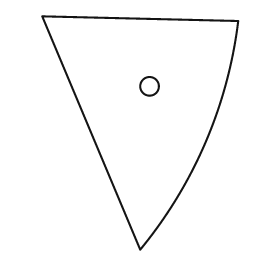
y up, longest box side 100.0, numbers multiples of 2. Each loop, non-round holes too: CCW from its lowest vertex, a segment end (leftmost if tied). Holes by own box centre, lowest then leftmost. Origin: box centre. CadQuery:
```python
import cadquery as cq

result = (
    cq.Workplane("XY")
    .moveTo(0.0, -50.0)
    .threePointArc((28.0, -4.0), (42.0, 48.0))
    .lineTo(-42.0, 50.0)
    .close()
    .moveTo(4.0, 20.0)
    .circle(4.0)
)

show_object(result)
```